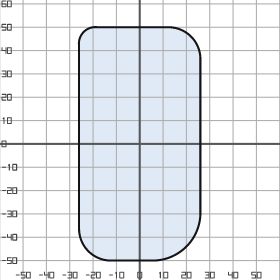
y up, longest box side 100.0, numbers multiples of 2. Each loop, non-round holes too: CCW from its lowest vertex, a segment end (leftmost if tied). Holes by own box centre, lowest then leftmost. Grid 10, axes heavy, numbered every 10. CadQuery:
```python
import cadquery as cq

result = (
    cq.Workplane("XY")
    .moveTo(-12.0, -50.0)
    .lineTo(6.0, -50.0)
    .threePointArc((20.0, -44.0), (26.0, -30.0))
    .lineTo(26.0, 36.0)
    .threePointArc((22.0, 46.0), (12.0, 50.0))
    .lineTo(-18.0, 50.0)
    .threePointArc((-24.0, 48.0), (-26.0, 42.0))
    .lineTo(-26.0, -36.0)
    .threePointArc((-22.0, -46.0), (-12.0, -50.0))
    .close()
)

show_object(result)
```